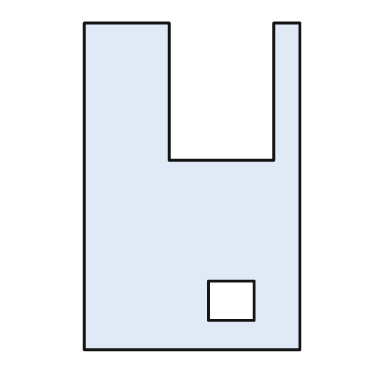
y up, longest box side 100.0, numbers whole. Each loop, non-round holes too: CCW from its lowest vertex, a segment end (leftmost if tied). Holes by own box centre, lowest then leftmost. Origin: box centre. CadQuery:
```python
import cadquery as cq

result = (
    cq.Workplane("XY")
    .moveTo(-33.0, -50.0)
    .lineTo(33.0, -50.0)
    .lineTo(33.0, 50.0)
    .lineTo(25.0, 50.0)
    .lineTo(25.0, 8.0)
    .lineTo(-7.0, 8.0)
    .lineTo(-7.0, 50.0)
    .lineTo(-33.0, 50.0)
    .close()
    .moveTo(5.0, -41.0)
    .lineTo(19.0, -41.0)
    .lineTo(19.0, -29.0)
    .lineTo(5.0, -29.0)
    .close()
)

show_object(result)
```